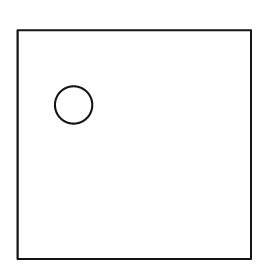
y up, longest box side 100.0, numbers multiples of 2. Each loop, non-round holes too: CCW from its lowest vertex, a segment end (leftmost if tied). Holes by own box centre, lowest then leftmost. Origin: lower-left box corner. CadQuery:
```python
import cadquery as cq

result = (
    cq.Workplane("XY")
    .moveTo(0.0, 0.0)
    .lineTo(100.0, 0.0)
    .lineTo(100.0, 98.0)
    .lineTo(0.0, 98.0)
    .close()
    .moveTo(24.0, 66.0)
    .circle(8.0)
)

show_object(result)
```